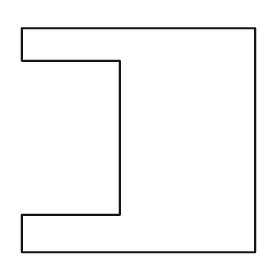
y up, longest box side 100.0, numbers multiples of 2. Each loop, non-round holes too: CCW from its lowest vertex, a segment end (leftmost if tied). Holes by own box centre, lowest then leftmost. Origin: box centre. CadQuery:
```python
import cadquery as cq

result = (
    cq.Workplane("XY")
    .moveTo(-50.0, -48.0)
    .lineTo(50.0, -48.0)
    .lineTo(50.0, 48.0)
    .lineTo(-50.0, 48.0)
    .lineTo(-50.0, 34.0)
    .lineTo(-8.0, 34.0)
    .lineTo(-8.0, -32.0)
    .lineTo(-50.0, -32.0)
    .close()
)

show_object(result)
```